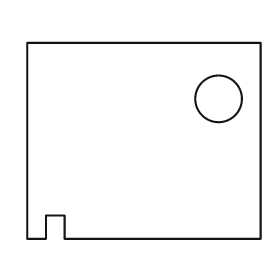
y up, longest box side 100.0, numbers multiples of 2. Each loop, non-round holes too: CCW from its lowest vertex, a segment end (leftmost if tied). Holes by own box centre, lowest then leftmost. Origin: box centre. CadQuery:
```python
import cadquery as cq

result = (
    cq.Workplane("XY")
    .moveTo(-50.0, -42.0)
    .lineTo(-42.0, -42.0)
    .lineTo(-42.0, -32.0)
    .lineTo(-34.0, -32.0)
    .lineTo(-34.0, -42.0)
    .lineTo(50.0, -42.0)
    .lineTo(50.0, 42.0)
    .lineTo(-50.0, 42.0)
    .close()
    .moveTo(32.0, 18.0)
    .circle(10.0)
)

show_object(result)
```